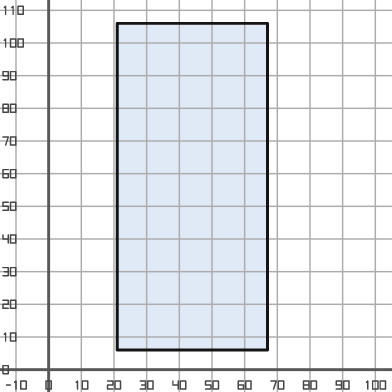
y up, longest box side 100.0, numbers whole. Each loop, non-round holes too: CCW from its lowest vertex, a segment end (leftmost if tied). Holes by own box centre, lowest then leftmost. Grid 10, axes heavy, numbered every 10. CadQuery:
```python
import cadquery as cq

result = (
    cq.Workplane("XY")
    .moveTo(21.0, 6.0)
    .lineTo(67.0, 6.0)
    .lineTo(67.0, 106.0)
    .lineTo(21.0, 106.0)
    .close()
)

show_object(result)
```